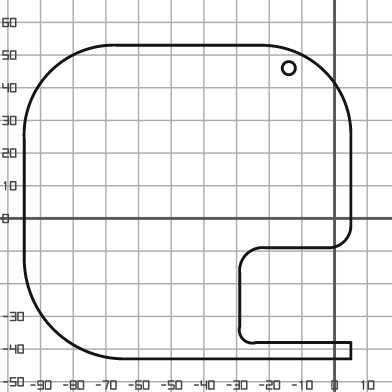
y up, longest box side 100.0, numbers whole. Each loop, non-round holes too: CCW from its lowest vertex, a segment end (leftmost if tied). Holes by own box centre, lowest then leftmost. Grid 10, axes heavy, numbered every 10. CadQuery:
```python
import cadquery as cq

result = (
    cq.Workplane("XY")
    .moveTo(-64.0, -43.0)
    .lineTo(5.0, -43.0)
    .lineTo(5.0, -38.0)
    .lineTo(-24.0, -38.0)
    .threePointArc((-28.0, -37.0), (-29.0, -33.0))
    .lineTo(-29.0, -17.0)
    .threePointArc((-27.0, -11.0), (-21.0, -9.0))
    .lineTo(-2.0, -9.0)
    .threePointArc((3.0, -7.0), (5.0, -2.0))
    .lineTo(5.0, 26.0)
    .threePointArc((-3.0, 45.0), (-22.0, 53.0))
    .lineTo(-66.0, 53.0)
    .threePointArc((-87.0, 45.0), (-95.0, 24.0))
    .lineTo(-95.0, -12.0)
    .threePointArc((-86.0, -34.0), (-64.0, -43.0))
    .close()
    .moveTo(-14.0, 46.0)
    .circle(2.0)
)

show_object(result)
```